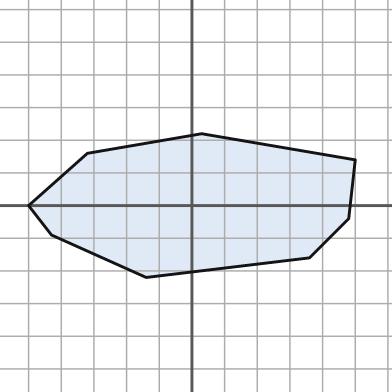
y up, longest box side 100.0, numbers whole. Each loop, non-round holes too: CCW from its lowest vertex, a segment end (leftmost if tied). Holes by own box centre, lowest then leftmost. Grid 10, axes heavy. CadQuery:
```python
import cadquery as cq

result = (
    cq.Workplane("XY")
    .moveTo(-14.0, -22.0)
    .lineTo(36.0, -16.0)
    .lineTo(48.0, -4.0)
    .lineTo(50.0, 14.0)
    .lineTo(3.0, 22.0)
    .lineTo(-32.0, 16.0)
    .lineTo(-50.0, 0.0)
    .lineTo(-43.0, -9.0)
    .close()
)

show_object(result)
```